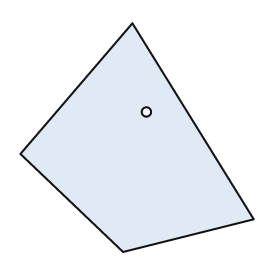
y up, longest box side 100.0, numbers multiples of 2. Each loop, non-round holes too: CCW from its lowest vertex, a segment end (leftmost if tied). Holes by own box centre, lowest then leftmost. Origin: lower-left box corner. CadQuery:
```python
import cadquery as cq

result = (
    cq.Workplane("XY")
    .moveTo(44.0, 0.0)
    .lineTo(100.0, 14.0)
    .lineTo(48.0, 98.0)
    .lineTo(0.0, 42.0)
    .close()
    .moveTo(54.0, 60.0)
    .circle(2.0)
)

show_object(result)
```